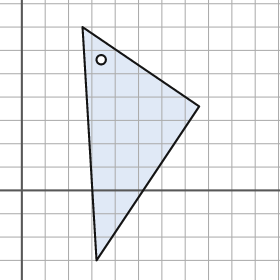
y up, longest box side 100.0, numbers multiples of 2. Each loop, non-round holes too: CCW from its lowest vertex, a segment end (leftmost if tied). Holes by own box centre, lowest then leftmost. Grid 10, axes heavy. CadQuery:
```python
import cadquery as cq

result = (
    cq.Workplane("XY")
    .moveTo(32.0, -30.0)
    .lineTo(76.0, 36.0)
    .lineTo(26.0, 70.0)
    .close()
    .moveTo(34.0, 56.0)
    .circle(2.0)
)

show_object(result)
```